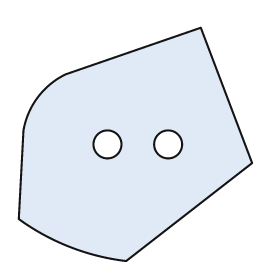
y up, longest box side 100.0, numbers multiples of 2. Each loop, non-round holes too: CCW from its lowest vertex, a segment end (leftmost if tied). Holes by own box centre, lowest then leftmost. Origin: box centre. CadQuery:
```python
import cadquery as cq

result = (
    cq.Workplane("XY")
    .moveTo(-4.0, -50.0)
    .lineTo(50.0, -8.0)
    .lineTo(28.0, 50.0)
    .lineTo(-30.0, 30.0)
    .threePointArc((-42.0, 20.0), (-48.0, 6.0))
    .lineTo(-50.0, -32.0)
    .threePointArc((-28.0, -44.0), (-4.0, -50.0))
    .close()
    .moveTo(-12.0, 0.0)
    .circle(6.0)
    .moveTo(14.0, 0.0)
    .circle(6.0)
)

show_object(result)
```